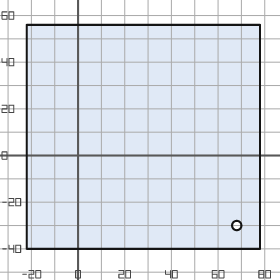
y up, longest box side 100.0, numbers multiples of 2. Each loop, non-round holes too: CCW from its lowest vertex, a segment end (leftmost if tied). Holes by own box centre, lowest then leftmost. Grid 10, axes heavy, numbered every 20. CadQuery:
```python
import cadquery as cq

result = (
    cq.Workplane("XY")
    .moveTo(-22.0, -40.0)
    .lineTo(78.0, -40.0)
    .lineTo(78.0, 56.0)
    .lineTo(-22.0, 56.0)
    .close()
    .moveTo(68.0, -30.0)
    .circle(2.0)
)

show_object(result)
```